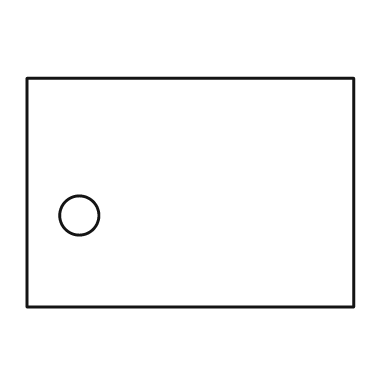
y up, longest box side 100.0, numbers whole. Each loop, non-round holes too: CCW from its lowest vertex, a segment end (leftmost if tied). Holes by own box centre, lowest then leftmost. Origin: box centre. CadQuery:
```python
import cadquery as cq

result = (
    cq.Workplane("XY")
    .moveTo(-50.0, -35.0)
    .lineTo(50.0, -35.0)
    .lineTo(50.0, 35.0)
    .lineTo(-50.0, 35.0)
    .close()
    .moveTo(-34.0, -7.0)
    .circle(6.0)
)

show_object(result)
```